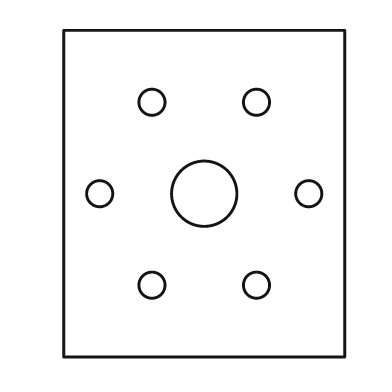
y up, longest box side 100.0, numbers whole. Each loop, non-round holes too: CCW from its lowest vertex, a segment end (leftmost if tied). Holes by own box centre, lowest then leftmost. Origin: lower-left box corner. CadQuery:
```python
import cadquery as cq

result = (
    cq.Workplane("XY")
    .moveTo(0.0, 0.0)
    .lineTo(86.0, 0.0)
    .lineTo(86.0, 100.0)
    .lineTo(0.0, 100.0)
    .close()
    .moveTo(27.0, 22.0)
    .circle(4.0)
    .moveTo(59.0, 22.0)
    .circle(4.0)
    .moveTo(11.0, 50.0)
    .circle(4.0)
    .moveTo(43.0, 50.0)
    .circle(10.0)
    .moveTo(75.0, 50.0)
    .circle(4.0)
    .moveTo(27.0, 78.0)
    .circle(4.0)
    .moveTo(59.0, 78.0)
    .circle(4.0)
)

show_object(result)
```